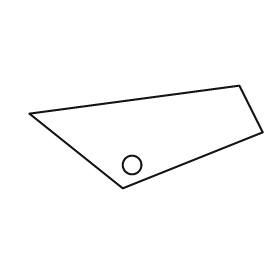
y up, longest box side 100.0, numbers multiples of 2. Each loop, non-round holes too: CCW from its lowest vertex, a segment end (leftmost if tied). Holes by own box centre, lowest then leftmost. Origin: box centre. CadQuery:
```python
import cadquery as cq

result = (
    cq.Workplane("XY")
    .moveTo(-10.0, -22.0)
    .lineTo(50.0, 2.0)
    .lineTo(40.0, 22.0)
    .lineTo(-50.0, 10.0)
    .close()
    .moveTo(-6.0, -12.0)
    .circle(4.0)
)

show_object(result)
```